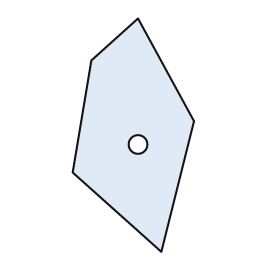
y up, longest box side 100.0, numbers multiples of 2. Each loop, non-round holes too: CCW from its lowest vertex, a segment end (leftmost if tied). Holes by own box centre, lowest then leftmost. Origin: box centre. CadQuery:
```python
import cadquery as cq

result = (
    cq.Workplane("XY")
    .moveTo(12.0, -50.0)
    .lineTo(26.0, 6.0)
    .lineTo(2.0, 50.0)
    .lineTo(-18.0, 32.0)
    .lineTo(-26.0, -16.0)
    .close()
    .moveTo(2.0, -4.0)
    .circle(4.0)
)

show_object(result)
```